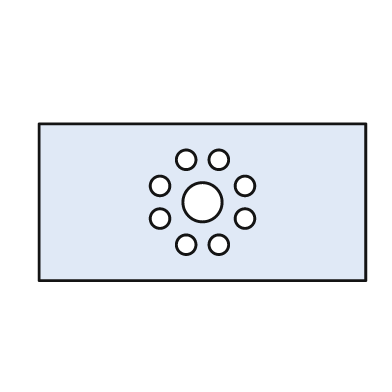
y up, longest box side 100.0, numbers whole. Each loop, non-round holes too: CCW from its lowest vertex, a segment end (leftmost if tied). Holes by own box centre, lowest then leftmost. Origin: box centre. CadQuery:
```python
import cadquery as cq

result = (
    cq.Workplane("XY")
    .moveTo(-50.0, -24.0)
    .lineTo(50.0, -24.0)
    .lineTo(50.0, 24.0)
    .lineTo(-50.0, 24.0)
    .close()
    .moveTo(-5.0, -13.0)
    .circle(3.0)
    .moveTo(5.0, -13.0)
    .circle(3.0)
    .moveTo(-13.0, -5.0)
    .circle(3.0)
    .moveTo(13.0, -5.0)
    .circle(3.0)
    .moveTo(0.0, 0.0)
    .circle(6.0)
    .moveTo(-13.0, 5.0)
    .circle(3.0)
    .moveTo(13.0, 5.0)
    .circle(3.0)
    .moveTo(-5.0, 13.0)
    .circle(3.0)
    .moveTo(5.0, 13.0)
    .circle(3.0)
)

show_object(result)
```